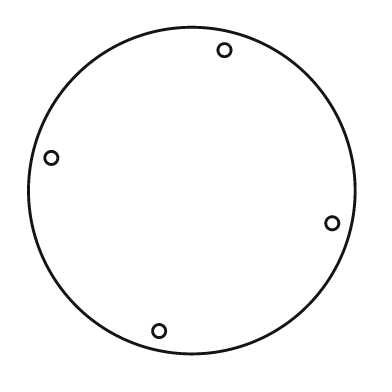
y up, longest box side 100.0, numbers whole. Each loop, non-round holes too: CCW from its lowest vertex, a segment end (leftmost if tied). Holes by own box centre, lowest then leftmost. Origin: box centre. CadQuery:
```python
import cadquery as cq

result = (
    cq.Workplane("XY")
    .moveTo(0.0, 0.0)
    .circle(50.0)
    .moveTo(-10.0, -43.0)
    .circle(2.0)
    .moveTo(43.0, -10.0)
    .circle(2.0)
    .moveTo(-43.0, 10.0)
    .circle(2.0)
    .moveTo(10.0, 43.0)
    .circle(2.0)
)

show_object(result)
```